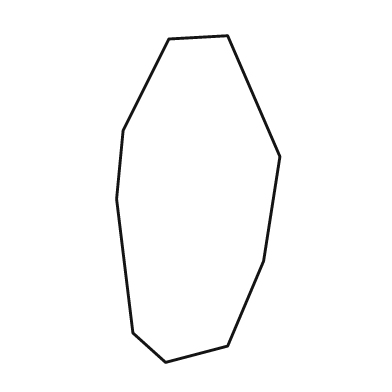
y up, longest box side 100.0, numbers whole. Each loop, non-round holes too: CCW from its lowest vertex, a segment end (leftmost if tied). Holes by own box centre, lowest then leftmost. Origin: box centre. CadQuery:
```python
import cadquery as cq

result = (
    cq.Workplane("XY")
    .moveTo(-10.0, -50.0)
    .lineTo(9.0, -45.0)
    .lineTo(20.0, -19.0)
    .lineTo(25.0, 13.0)
    .lineTo(9.0, 50.0)
    .lineTo(-9.0, 49.0)
    .lineTo(-23.0, 21.0)
    .lineTo(-25.0, 0.0)
    .lineTo(-20.0, -41.0)
    .close()
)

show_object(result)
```